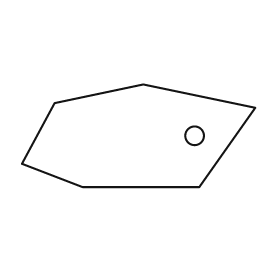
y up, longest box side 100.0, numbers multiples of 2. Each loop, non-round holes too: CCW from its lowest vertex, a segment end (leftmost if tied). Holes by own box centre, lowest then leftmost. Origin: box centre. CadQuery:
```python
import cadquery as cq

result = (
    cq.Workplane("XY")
    .moveTo(-24.0, -22.0)
    .lineTo(26.0, -22.0)
    .lineTo(50.0, 12.0)
    .lineTo(2.0, 22.0)
    .lineTo(-36.0, 14.0)
    .lineTo(-50.0, -12.0)
    .close()
    .moveTo(24.0, 0.0)
    .circle(4.0)
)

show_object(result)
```